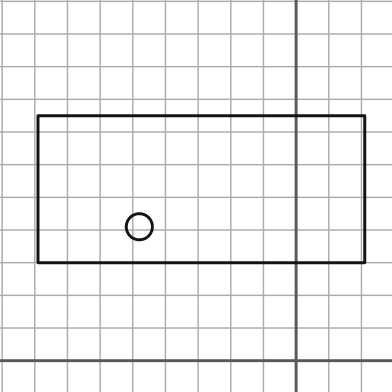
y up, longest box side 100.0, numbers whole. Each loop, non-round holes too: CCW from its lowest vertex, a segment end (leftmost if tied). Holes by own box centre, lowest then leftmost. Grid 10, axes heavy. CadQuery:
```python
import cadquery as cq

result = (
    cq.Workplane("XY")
    .moveTo(-79.0, 30.0)
    .lineTo(21.0, 30.0)
    .lineTo(21.0, 75.0)
    .lineTo(-79.0, 75.0)
    .close()
    .moveTo(-48.0, 41.0)
    .circle(4.0)
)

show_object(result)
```